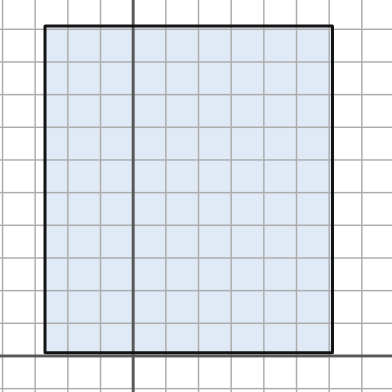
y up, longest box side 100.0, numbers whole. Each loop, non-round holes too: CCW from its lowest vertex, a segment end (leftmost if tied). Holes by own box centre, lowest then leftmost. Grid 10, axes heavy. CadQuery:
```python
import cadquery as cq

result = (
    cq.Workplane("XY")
    .moveTo(-27.0, 1.0)
    .lineTo(61.0, 1.0)
    .lineTo(61.0, 101.0)
    .lineTo(-27.0, 101.0)
    .close()
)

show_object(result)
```